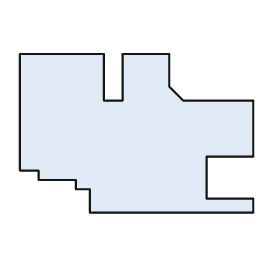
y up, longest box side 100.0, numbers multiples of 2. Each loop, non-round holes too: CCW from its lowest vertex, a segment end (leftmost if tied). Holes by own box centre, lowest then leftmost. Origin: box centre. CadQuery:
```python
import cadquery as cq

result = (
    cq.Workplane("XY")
    .moveTo(-20.0, -34.0)
    .lineTo(50.0, -34.0)
    .lineTo(50.0, -28.0)
    .lineTo(30.0, -28.0)
    .lineTo(30.0, -10.0)
    .lineTo(50.0, -10.0)
    .lineTo(50.0, 14.0)
    .lineTo(20.0, 14.0)
    .lineTo(14.0, 20.0)
    .lineTo(14.0, 34.0)
    .lineTo(-6.0, 34.0)
    .lineTo(-6.0, 14.0)
    .lineTo(-14.0, 14.0)
    .lineTo(-14.0, 34.0)
    .lineTo(-50.0, 34.0)
    .lineTo(-50.0, -16.0)
    .lineTo(-42.0, -16.0)
    .lineTo(-42.0, -20.0)
    .lineTo(-26.0, -20.0)
    .lineTo(-26.0, -24.0)
    .lineTo(-20.0, -24.0)
    .close()
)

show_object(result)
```